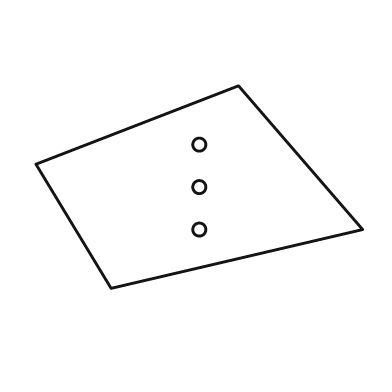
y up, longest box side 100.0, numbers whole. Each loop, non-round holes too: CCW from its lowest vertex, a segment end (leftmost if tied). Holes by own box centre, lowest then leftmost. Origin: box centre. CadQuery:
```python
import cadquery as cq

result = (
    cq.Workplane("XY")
    .moveTo(-27.0, -31.0)
    .lineTo(50.0, -13.0)
    .lineTo(12.0, 31.0)
    .lineTo(-50.0, 7.0)
    .close()
    .moveTo(0.0, -13.0)
    .circle(2.0)
    .moveTo(0.0, 0.0)
    .circle(2.0)
    .moveTo(0.0, 13.0)
    .circle(2.0)
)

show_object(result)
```